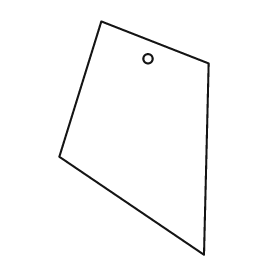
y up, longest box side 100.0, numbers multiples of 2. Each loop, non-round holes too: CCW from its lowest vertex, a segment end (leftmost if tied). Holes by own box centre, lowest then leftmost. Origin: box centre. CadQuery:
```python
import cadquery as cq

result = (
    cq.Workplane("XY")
    .moveTo(30.0, -50.0)
    .lineTo(32.0, 32.0)
    .lineTo(-14.0, 50.0)
    .lineTo(-32.0, -8.0)
    .close()
    .moveTo(6.0, 34.0)
    .circle(2.0)
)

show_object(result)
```